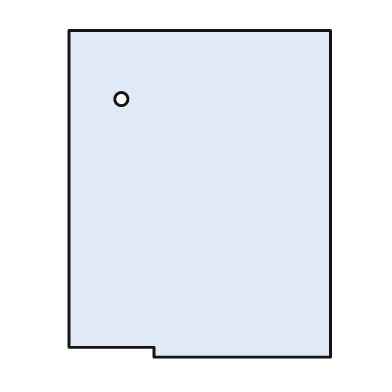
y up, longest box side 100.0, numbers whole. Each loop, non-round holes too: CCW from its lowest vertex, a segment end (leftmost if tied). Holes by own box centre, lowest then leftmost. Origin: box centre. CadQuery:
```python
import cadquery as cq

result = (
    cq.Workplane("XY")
    .moveTo(-14.0, -50.0)
    .lineTo(40.0, -50.0)
    .lineTo(40.0, 50.0)
    .lineTo(-40.0, 50.0)
    .lineTo(-40.0, -47.0)
    .lineTo(-14.0, -47.0)
    .close()
    .moveTo(-24.0, 29.0)
    .circle(2.0)
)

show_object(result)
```